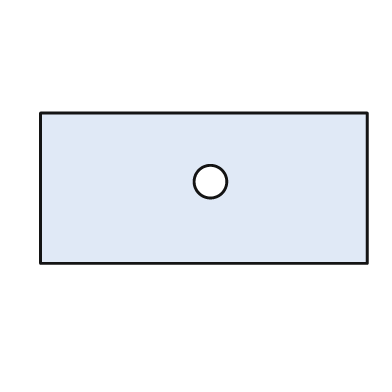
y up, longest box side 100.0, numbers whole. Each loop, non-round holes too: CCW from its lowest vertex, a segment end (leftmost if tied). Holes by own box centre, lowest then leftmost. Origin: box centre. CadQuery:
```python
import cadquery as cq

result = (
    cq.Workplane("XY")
    .moveTo(-50.0, -23.0)
    .lineTo(50.0, -23.0)
    .lineTo(50.0, 23.0)
    .lineTo(-50.0, 23.0)
    .close()
    .moveTo(2.0, 2.0)
    .circle(5.0)
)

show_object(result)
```